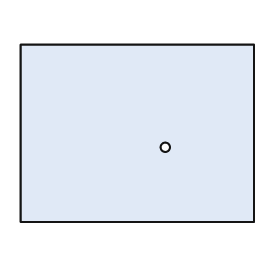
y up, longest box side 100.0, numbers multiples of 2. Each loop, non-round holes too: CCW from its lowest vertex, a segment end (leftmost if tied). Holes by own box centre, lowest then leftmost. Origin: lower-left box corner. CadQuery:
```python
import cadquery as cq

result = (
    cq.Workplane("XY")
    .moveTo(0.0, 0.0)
    .lineTo(100.0, 0.0)
    .lineTo(100.0, 76.0)
    .lineTo(0.0, 76.0)
    .close()
    .moveTo(62.0, 32.0)
    .circle(2.0)
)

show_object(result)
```